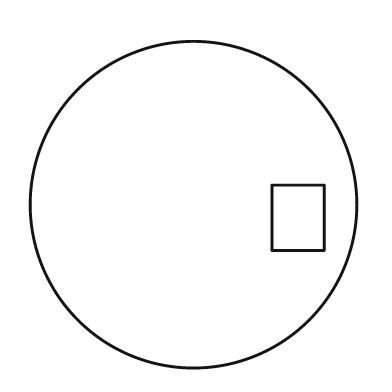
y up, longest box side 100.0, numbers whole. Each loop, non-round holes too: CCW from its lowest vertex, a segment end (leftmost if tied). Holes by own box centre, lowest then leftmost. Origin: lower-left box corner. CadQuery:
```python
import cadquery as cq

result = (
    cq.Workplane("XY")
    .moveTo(50.0, 50.0)
    .circle(50.0)
    .moveTo(74.0, 36.0)
    .lineTo(90.0, 36.0)
    .lineTo(90.0, 56.0)
    .lineTo(74.0, 56.0)
    .close()
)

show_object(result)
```